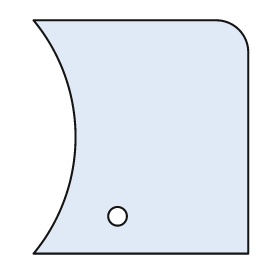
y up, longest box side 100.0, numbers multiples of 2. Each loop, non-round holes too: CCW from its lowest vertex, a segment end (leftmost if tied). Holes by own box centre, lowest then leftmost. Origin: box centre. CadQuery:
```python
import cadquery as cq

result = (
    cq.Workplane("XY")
    .moveTo(-46.0, -50.0)
    .lineTo(46.0, -50.0)
    .lineTo(46.0, 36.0)
    .threePointArc((42.0, 46.0), (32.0, 50.0))
    .lineTo(-46.0, 50.0)
    .threePointArc((-28.0, 0.0), (-46.0, -50.0))
    .close()
    .moveTo(-10.0, -34.0)
    .circle(4.0)
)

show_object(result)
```